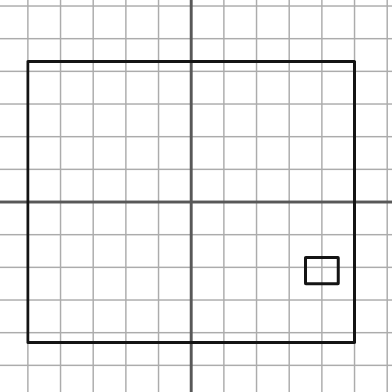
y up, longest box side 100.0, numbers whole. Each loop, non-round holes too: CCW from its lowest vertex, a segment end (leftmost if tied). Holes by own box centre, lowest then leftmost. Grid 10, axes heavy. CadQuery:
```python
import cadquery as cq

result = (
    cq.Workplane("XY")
    .moveTo(-50.0, -43.0)
    .lineTo(50.0, -43.0)
    .lineTo(50.0, 43.0)
    .lineTo(-50.0, 43.0)
    .close()
    .moveTo(35.0, -25.0)
    .lineTo(45.0, -25.0)
    .lineTo(45.0, -17.0)
    .lineTo(35.0, -17.0)
    .close()
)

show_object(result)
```